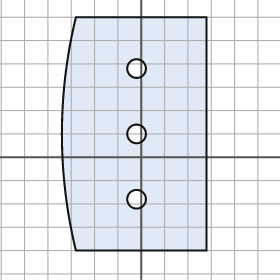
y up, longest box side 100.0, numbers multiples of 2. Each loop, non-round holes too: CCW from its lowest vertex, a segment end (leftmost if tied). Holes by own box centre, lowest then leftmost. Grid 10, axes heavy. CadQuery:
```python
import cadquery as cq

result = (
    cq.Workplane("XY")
    .moveTo(-28.0, -40.0)
    .lineTo(28.0, -40.0)
    .lineTo(28.0, 60.0)
    .lineTo(-28.0, 60.0)
    .threePointArc((-34.0, 10.0), (-28.0, -40.0))
    .close()
    .moveTo(-2.0, -18.0)
    .circle(4.0)
    .moveTo(-2.0, 10.0)
    .circle(4.0)
    .moveTo(-2.0, 38.0)
    .circle(4.0)
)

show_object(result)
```